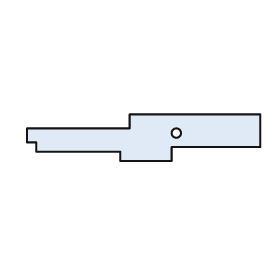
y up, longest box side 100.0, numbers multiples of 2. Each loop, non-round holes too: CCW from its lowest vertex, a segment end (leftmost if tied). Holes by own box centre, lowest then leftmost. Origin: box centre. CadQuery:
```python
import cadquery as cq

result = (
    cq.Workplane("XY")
    .moveTo(-10.0, -10.0)
    .lineTo(12.0, -10.0)
    .lineTo(12.0, -4.0)
    .lineTo(50.0, -4.0)
    .lineTo(50.0, 10.0)
    .lineTo(-6.0, 10.0)
    .lineTo(-6.0, 4.0)
    .lineTo(-50.0, 4.0)
    .lineTo(-50.0, -2.0)
    .lineTo(-46.0, -2.0)
    .lineTo(-46.0, -6.0)
    .lineTo(-10.0, -6.0)
    .close()
    .moveTo(14.0, 2.0)
    .circle(2.0)
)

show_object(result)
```